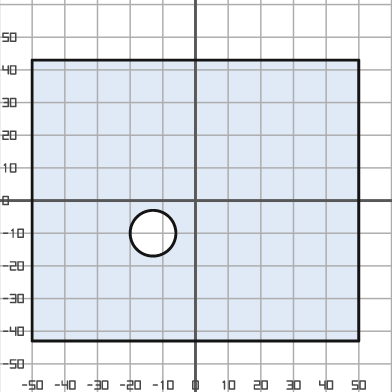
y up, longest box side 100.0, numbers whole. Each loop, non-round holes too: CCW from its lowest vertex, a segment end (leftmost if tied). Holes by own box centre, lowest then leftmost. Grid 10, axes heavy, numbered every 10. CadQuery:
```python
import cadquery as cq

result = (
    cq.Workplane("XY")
    .moveTo(-50.0, -43.0)
    .lineTo(50.0, -43.0)
    .lineTo(50.0, 43.0)
    .lineTo(-50.0, 43.0)
    .close()
    .moveTo(-13.0, -10.0)
    .circle(7.0)
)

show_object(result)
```